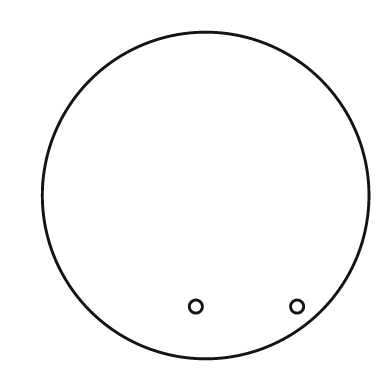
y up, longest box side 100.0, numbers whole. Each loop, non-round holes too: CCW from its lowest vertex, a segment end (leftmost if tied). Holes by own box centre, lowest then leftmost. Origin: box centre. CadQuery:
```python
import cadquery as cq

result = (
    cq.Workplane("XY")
    .moveTo(0.0, 0.0)
    .circle(50.0)
    .moveTo(-3.0, -34.0)
    .circle(2.0)
    .moveTo(28.0, -34.0)
    .circle(2.0)
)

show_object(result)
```